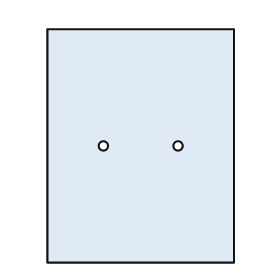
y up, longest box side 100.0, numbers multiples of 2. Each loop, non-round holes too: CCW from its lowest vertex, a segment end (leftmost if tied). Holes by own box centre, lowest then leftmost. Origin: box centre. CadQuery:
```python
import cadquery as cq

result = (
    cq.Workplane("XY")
    .moveTo(-40.0, -50.0)
    .lineTo(40.0, -50.0)
    .lineTo(40.0, 50.0)
    .lineTo(-40.0, 50.0)
    .close()
    .moveTo(-16.0, 0.0)
    .circle(2.0)
    .moveTo(16.0, 0.0)
    .circle(2.0)
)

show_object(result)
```